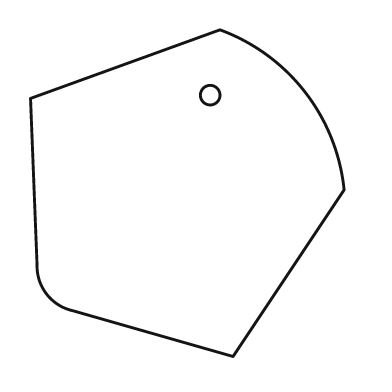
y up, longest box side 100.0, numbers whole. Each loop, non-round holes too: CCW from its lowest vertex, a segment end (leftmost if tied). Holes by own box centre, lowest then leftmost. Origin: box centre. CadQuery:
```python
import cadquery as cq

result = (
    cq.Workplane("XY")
    .moveTo(14.0, -50.0)
    .lineTo(48.0, 1.0)
    .threePointArc((36.0, 31.0), (10.0, 50.0))
    .lineTo(-48.0, 29.0)
    .lineTo(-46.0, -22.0)
    .threePointArc((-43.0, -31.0), (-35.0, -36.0))
    .close()
    .moveTo(7.0, 30.0)
    .circle(3.0)
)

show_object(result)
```